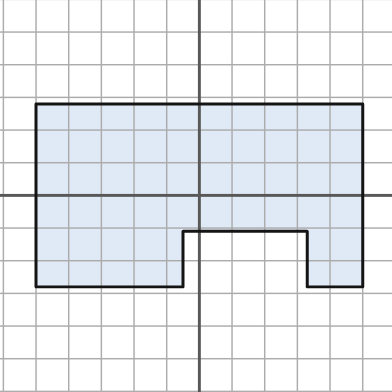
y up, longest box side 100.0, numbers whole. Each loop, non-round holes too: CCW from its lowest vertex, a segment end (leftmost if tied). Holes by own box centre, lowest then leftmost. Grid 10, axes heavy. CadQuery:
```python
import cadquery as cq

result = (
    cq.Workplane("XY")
    .moveTo(-50.0, -28.0)
    .lineTo(-5.0, -28.0)
    .lineTo(-5.0, -11.0)
    .lineTo(33.0, -11.0)
    .lineTo(33.0, -28.0)
    .lineTo(50.0, -28.0)
    .lineTo(50.0, 28.0)
    .lineTo(-50.0, 28.0)
    .close()
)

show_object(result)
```